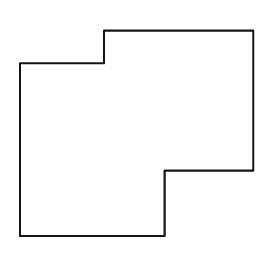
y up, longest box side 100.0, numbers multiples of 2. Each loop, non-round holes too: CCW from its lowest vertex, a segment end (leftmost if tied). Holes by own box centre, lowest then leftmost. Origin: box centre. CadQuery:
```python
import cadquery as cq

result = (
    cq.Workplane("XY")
    .moveTo(-50.0, -44.0)
    .lineTo(12.0, -44.0)
    .lineTo(12.0, -16.0)
    .lineTo(50.0, -16.0)
    .lineTo(50.0, 44.0)
    .lineTo(-14.0, 44.0)
    .lineTo(-14.0, 30.0)
    .lineTo(-50.0, 30.0)
    .close()
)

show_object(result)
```